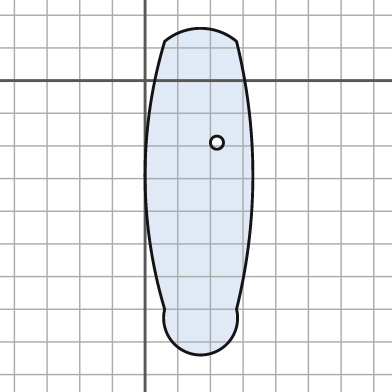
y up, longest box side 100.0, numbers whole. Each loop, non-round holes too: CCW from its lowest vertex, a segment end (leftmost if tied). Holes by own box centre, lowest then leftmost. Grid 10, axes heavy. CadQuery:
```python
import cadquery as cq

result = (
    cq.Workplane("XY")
    .moveTo(6.0, -70.0)
    .threePointArc((17.0, -84.0), (28.0, -70.0))
    .threePointArc((33.0, -29.0), (28.0, 12.0))
    .threePointArc((17.0, 16.0), (6.0, 12.0))
    .threePointArc((0.0, -29.0), (6.0, -70.0))
    .close()
    .moveTo(22.0, -19.0)
    .circle(2.0)
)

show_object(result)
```